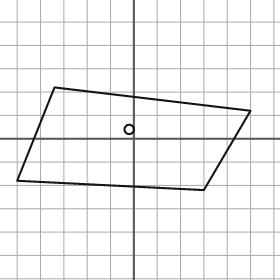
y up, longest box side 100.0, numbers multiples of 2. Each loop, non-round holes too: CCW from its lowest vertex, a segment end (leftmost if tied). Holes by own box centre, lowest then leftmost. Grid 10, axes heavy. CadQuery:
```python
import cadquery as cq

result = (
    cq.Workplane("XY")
    .moveTo(30.0, -22.0)
    .lineTo(50.0, 12.0)
    .lineTo(-34.0, 22.0)
    .lineTo(-50.0, -18.0)
    .close()
    .moveTo(-2.0, 4.0)
    .circle(2.0)
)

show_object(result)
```